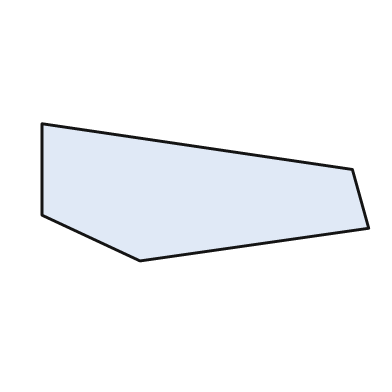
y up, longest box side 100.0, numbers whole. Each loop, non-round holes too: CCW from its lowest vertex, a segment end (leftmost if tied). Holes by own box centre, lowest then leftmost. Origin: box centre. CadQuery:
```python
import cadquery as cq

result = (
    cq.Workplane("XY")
    .moveTo(-20.0, -21.0)
    .lineTo(50.0, -11.0)
    .lineTo(45.0, 7.0)
    .lineTo(-50.0, 21.0)
    .lineTo(-50.0, -7.0)
    .close()
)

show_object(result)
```